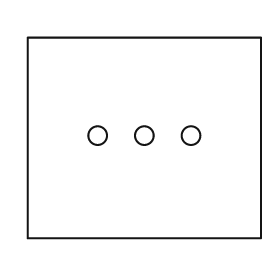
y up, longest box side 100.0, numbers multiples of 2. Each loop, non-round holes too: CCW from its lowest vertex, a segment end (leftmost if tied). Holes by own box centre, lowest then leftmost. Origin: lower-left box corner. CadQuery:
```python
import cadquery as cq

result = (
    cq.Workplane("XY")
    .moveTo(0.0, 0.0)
    .lineTo(100.0, 0.0)
    .lineTo(100.0, 86.0)
    .lineTo(0.0, 86.0)
    .close()
    .moveTo(30.0, 44.0)
    .circle(4.0)
    .moveTo(50.0, 44.0)
    .circle(4.0)
    .moveTo(70.0, 44.0)
    .circle(4.0)
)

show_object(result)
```